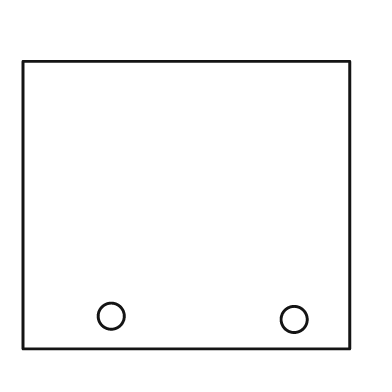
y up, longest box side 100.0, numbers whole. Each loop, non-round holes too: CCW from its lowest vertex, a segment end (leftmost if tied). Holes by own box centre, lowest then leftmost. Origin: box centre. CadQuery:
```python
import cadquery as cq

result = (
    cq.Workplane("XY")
    .moveTo(-50.0, -44.0)
    .lineTo(50.0, -44.0)
    .lineTo(50.0, 44.0)
    .lineTo(-50.0, 44.0)
    .close()
    .moveTo(33.0, -35.0)
    .circle(4.0)
    .moveTo(-23.0, -34.0)
    .circle(4.0)
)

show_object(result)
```